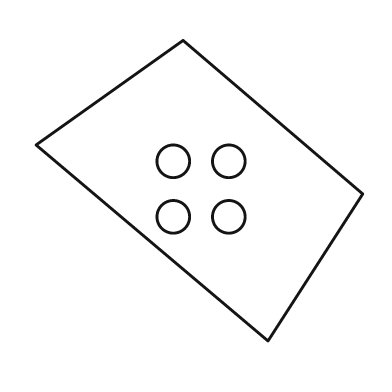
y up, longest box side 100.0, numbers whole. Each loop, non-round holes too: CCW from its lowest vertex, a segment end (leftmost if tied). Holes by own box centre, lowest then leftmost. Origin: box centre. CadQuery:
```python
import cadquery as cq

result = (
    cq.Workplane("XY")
    .moveTo(21.0, -46.0)
    .lineTo(50.0, -1.0)
    .lineTo(-5.0, 46.0)
    .lineTo(-50.0, 14.0)
    .close()
    .moveTo(-8.0, -8.0)
    .circle(5.0)
    .moveTo(9.0, -8.0)
    .circle(5.0)
    .moveTo(-8.0, 9.0)
    .circle(5.0)
    .moveTo(9.0, 9.0)
    .circle(5.0)
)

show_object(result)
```